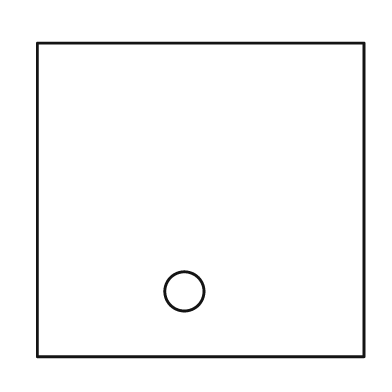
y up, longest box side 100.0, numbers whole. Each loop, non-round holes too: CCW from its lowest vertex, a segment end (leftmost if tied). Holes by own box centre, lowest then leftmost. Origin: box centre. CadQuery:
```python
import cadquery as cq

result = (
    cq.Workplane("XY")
    .moveTo(-50.0, -48.0)
    .lineTo(50.0, -48.0)
    .lineTo(50.0, 48.0)
    .lineTo(-50.0, 48.0)
    .close()
    .moveTo(-5.0, -28.0)
    .circle(6.0)
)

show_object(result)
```